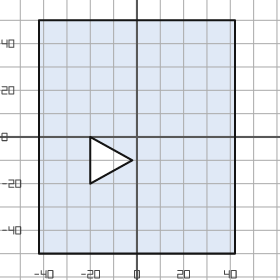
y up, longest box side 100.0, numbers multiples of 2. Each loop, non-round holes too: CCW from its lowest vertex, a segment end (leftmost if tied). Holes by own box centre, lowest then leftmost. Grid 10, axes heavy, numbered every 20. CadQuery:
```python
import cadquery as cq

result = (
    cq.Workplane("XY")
    .moveTo(-42.0, -50.0)
    .lineTo(42.0, -50.0)
    .lineTo(42.0, 50.0)
    .lineTo(-42.0, 50.0)
    .close()
    .moveTo(-20.0, -20.0)
    .lineTo(-2.0, -10.0)
    .lineTo(-20.0, 0.0)
    .close()
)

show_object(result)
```